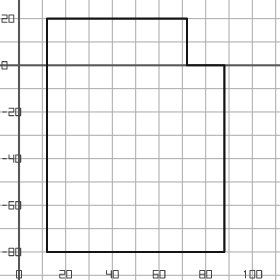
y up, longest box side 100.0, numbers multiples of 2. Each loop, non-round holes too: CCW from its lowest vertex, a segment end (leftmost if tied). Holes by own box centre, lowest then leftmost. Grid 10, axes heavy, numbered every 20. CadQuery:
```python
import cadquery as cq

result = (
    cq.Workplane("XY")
    .moveTo(12.0, -80.0)
    .lineTo(88.0, -80.0)
    .lineTo(88.0, 0.0)
    .lineTo(72.0, 0.0)
    .lineTo(72.0, 20.0)
    .lineTo(12.0, 20.0)
    .close()
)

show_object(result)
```